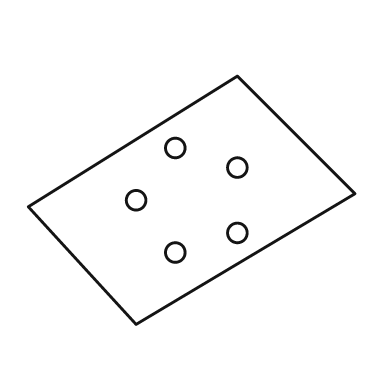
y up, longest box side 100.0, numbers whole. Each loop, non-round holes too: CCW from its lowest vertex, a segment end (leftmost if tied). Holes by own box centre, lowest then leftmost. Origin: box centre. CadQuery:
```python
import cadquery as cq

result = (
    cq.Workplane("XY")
    .moveTo(-17.0, -38.0)
    .lineTo(50.0, 2.0)
    .lineTo(14.0, 38.0)
    .lineTo(-50.0, -2.0)
    .close()
    .moveTo(-5.0, -16.0)
    .circle(3.0)
    .moveTo(14.0, -10.0)
    .circle(3.0)
    .moveTo(-17.0, 0.0)
    .circle(3.0)
    .moveTo(14.0, 10.0)
    .circle(3.0)
    .moveTo(-5.0, 16.0)
    .circle(3.0)
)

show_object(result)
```